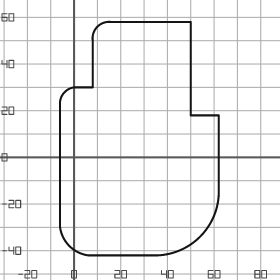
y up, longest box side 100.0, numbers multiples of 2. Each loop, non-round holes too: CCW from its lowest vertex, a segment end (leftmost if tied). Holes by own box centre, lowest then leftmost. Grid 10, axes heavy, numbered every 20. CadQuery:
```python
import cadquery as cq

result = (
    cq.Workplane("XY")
    .moveTo(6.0, -42.0)
    .lineTo(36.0, -42.0)
    .threePointArc((54.0, -34.0), (62.0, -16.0))
    .lineTo(62.0, 18.0)
    .lineTo(50.0, 18.0)
    .lineTo(50.0, 58.0)
    .lineTo(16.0, 58.0)
    .threePointArc((10.0, 56.0), (8.0, 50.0))
    .lineTo(8.0, 30.0)
    .lineTo(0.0, 30.0)
    .threePointArc((-4.0, 28.0), (-6.0, 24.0))
    .lineTo(-6.0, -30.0)
    .threePointArc((-2.0, -38.0), (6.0, -42.0))
    .close()
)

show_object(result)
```